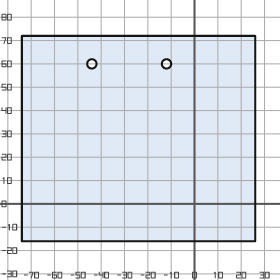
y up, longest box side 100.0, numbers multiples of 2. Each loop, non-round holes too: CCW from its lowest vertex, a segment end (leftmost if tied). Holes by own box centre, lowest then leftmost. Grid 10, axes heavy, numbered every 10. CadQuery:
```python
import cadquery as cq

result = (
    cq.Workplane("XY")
    .moveTo(-74.0, -16.0)
    .lineTo(26.0, -16.0)
    .lineTo(26.0, 72.0)
    .lineTo(-74.0, 72.0)
    .close()
    .moveTo(-44.0, 60.0)
    .circle(2.0)
    .moveTo(-12.0, 60.0)
    .circle(2.0)
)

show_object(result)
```